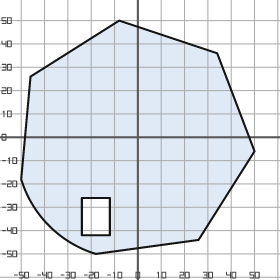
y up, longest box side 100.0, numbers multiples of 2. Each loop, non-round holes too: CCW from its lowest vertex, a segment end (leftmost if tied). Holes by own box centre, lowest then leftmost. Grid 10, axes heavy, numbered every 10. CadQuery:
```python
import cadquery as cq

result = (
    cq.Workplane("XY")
    .moveTo(-18.0, -50.0)
    .lineTo(26.0, -44.0)
    .lineTo(50.0, -6.0)
    .lineTo(34.0, 36.0)
    .lineTo(-8.0, 50.0)
    .lineTo(-46.0, 26.0)
    .lineTo(-50.0, -18.0)
    .threePointArc((-38.0, -38.0), (-18.0, -50.0))
    .close()
    .moveTo(-24.0, -42.0)
    .lineTo(-12.0, -42.0)
    .lineTo(-12.0, -26.0)
    .lineTo(-24.0, -26.0)
    .close()
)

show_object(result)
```